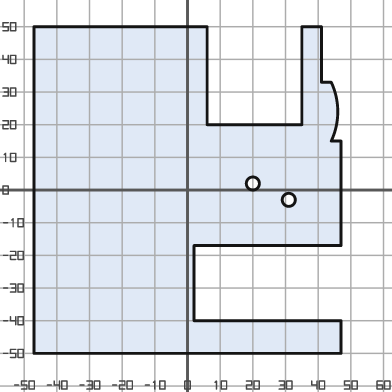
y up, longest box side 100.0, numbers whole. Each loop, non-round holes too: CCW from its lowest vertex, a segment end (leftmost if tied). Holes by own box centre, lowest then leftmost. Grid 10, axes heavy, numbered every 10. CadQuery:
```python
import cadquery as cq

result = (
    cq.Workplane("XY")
    .moveTo(-47.0, -50.0)
    .lineTo(47.0, -50.0)
    .lineTo(47.0, -40.0)
    .lineTo(2.0, -40.0)
    .lineTo(2.0, -17.0)
    .lineTo(47.0, -17.0)
    .lineTo(47.0, 15.0)
    .lineTo(44.0, 15.0)
    .threePointArc((46.0, 24.0), (44.0, 33.0))
    .lineTo(41.0, 33.0)
    .lineTo(41.0, 50.0)
    .lineTo(35.0, 50.0)
    .lineTo(35.0, 20.0)
    .lineTo(6.0, 20.0)
    .lineTo(6.0, 50.0)
    .lineTo(-47.0, 50.0)
    .close()
    .moveTo(31.0, -3.0)
    .circle(2.0)
    .moveTo(20.0, 2.0)
    .circle(2.0)
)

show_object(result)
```